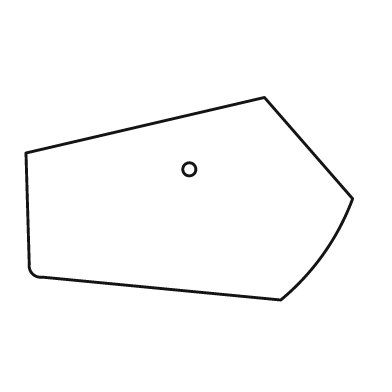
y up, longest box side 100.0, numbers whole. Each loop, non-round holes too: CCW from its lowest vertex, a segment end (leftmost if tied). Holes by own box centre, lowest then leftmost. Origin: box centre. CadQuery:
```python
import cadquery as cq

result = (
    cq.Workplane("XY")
    .moveTo(28.0, -31.0)
    .threePointArc((41.0, -17.0), (50.0, 0.0))
    .lineTo(23.0, 31.0)
    .lineTo(-50.0, 14.0)
    .lineTo(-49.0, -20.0)
    .threePointArc((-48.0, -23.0), (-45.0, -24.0))
    .close()
    .moveTo(0.0, 9.0)
    .circle(2.0)
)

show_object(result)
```